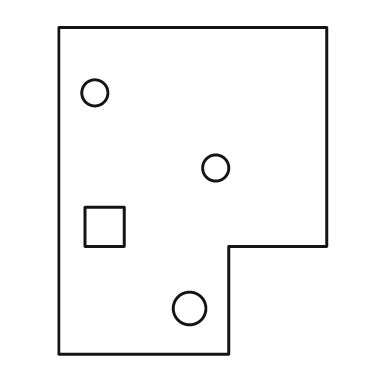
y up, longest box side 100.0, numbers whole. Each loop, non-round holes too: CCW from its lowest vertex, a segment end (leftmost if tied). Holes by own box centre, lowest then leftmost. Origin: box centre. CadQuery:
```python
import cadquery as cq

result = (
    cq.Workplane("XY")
    .moveTo(-41.0, -50.0)
    .lineTo(11.0, -50.0)
    .lineTo(11.0, -17.0)
    .lineTo(41.0, -17.0)
    .lineTo(41.0, 50.0)
    .lineTo(-41.0, 50.0)
    .close()
    .moveTo(-1.0, -36.0)
    .circle(5.0)
    .moveTo(-33.0, -17.0)
    .lineTo(-21.0, -17.0)
    .lineTo(-21.0, -5.0)
    .lineTo(-33.0, -5.0)
    .close()
    .moveTo(7.0, 7.0)
    .circle(4.0)
    .moveTo(-30.0, 30.0)
    .circle(4.0)
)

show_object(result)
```